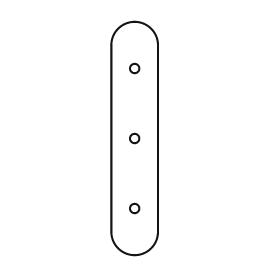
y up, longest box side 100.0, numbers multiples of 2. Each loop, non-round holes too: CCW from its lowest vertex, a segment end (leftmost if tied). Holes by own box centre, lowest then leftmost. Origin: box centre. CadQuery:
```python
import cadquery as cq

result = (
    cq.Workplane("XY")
    .moveTo(-10.0, -40.0)
    .threePointArc((0.0, -50.0), (10.0, -40.0))
    .lineTo(10.0, 40.0)
    .threePointArc((0.0, 50.0), (-10.0, 40.0))
    .close()
    .moveTo(0.0, -30.0)
    .circle(2.0)
    .moveTo(0.0, 0.0)
    .circle(2.0)
    .moveTo(0.0, 30.0)
    .circle(2.0)
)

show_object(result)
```